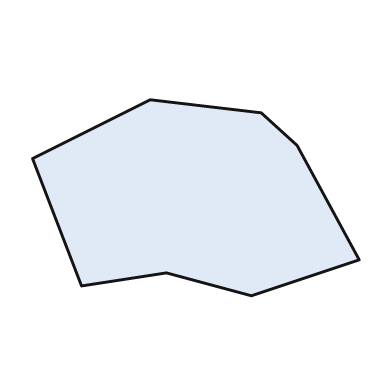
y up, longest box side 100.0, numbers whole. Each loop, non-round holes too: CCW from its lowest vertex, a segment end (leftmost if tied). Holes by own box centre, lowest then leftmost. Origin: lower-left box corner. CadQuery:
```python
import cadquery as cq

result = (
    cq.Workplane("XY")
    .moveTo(67.0, 0.0)
    .lineTo(100.0, 11.0)
    .lineTo(81.0, 46.0)
    .lineTo(70.0, 56.0)
    .lineTo(36.0, 60.0)
    .lineTo(0.0, 42.0)
    .lineTo(15.0, 3.0)
    .lineTo(41.0, 7.0)
    .close()
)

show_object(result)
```